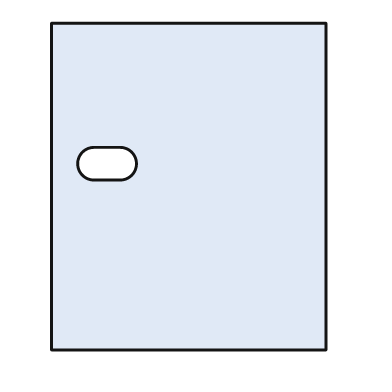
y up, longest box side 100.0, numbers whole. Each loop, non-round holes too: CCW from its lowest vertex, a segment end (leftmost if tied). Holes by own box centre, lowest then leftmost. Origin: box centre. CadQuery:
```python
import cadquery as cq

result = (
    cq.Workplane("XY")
    .moveTo(-42.0, -50.0)
    .lineTo(42.0, -50.0)
    .lineTo(42.0, 50.0)
    .lineTo(-42.0, 50.0)
    .close()
    .moveTo(-29.0, 2.0)
    .lineTo(-21.0, 2.0)
    .threePointArc((-16.0, 7.0), (-21.0, 12.0))
    .lineTo(-29.0, 12.0)
    .threePointArc((-34.0, 7.0), (-29.0, 2.0))
    .close()
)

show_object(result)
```